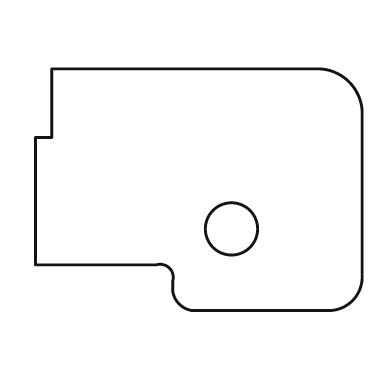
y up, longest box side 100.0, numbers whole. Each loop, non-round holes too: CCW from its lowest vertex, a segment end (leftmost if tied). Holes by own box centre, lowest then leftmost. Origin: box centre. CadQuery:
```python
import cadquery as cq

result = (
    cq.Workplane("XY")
    .moveTo(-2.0, -37.0)
    .lineTo(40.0, -37.0)
    .threePointArc((47.0, -34.0), (50.0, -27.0))
    .lineTo(50.0, 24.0)
    .threePointArc((46.0, 33.0), (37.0, 37.0))
    .lineTo(-45.0, 37.0)
    .lineTo(-45.0, 16.0)
    .lineTo(-50.0, 16.0)
    .lineTo(-50.0, -23.0)
    .lineTo(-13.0, -23.0)
    .threePointArc((-9.0, -24.0), (-8.0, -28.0))
    .lineTo(-8.0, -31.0)
    .threePointArc((-6.0, -35.0), (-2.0, -37.0))
    .close()
    .moveTo(10.0, -12.0)
    .circle(8.0)
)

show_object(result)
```